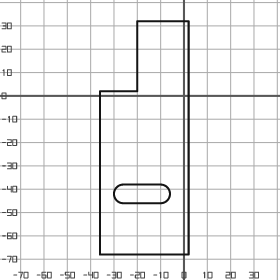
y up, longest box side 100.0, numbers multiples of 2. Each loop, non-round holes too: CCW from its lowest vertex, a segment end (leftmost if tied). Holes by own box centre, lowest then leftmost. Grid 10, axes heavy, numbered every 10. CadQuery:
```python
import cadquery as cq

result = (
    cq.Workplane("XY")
    .moveTo(-36.0, -68.0)
    .lineTo(2.0, -68.0)
    .lineTo(2.0, 32.0)
    .lineTo(-20.0, 32.0)
    .lineTo(-20.0, 2.0)
    .lineTo(-36.0, 2.0)
    .close()
    .moveTo(-26.0, -46.0)
    .lineTo(-10.0, -46.0)
    .threePointArc((-6.0, -42.0), (-10.0, -38.0))
    .lineTo(-26.0, -38.0)
    .threePointArc((-30.0, -42.0), (-26.0, -46.0))
    .close()
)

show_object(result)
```